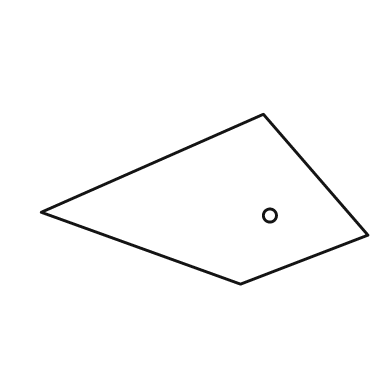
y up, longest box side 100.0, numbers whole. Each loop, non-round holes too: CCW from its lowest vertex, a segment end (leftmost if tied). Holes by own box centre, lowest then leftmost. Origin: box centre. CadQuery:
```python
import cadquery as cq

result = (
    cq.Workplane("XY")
    .moveTo(11.0, -26.0)
    .lineTo(50.0, -11.0)
    .lineTo(18.0, 26.0)
    .lineTo(-50.0, -4.0)
    .close()
    .moveTo(20.0, -5.0)
    .circle(2.0)
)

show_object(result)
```